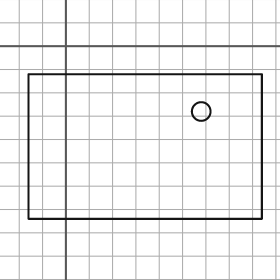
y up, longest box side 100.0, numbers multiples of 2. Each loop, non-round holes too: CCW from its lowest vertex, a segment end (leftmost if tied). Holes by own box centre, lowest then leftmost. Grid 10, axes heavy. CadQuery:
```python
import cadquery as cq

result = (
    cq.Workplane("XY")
    .moveTo(-16.0, -74.0)
    .lineTo(84.0, -74.0)
    .lineTo(84.0, -12.0)
    .lineTo(-16.0, -12.0)
    .close()
    .moveTo(58.0, -28.0)
    .circle(4.0)
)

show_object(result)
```